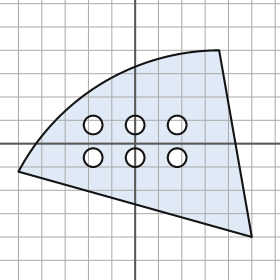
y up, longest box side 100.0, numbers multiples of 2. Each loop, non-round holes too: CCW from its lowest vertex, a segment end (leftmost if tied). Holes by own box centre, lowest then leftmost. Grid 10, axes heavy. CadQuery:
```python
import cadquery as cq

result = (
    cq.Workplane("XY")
    .moveTo(50.0, -40.0)
    .lineTo(36.0, 40.0)
    .threePointArc((-14.0, 26.0), (-50.0, -12.0))
    .close()
    .moveTo(-18.0, -6.0)
    .circle(4.0)
    .moveTo(0.0, -6.0)
    .circle(4.0)
    .moveTo(18.0, -6.0)
    .circle(4.0)
    .moveTo(-18.0, 8.0)
    .circle(4.0)
    .moveTo(0.0, 8.0)
    .circle(4.0)
    .moveTo(18.0, 8.0)
    .circle(4.0)
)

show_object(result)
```